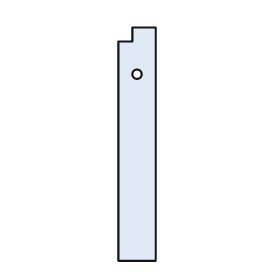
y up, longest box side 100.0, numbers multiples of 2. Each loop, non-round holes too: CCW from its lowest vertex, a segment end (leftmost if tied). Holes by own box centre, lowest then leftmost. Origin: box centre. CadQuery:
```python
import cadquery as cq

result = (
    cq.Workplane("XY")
    .moveTo(-8.0, -50.0)
    .lineTo(8.0, -50.0)
    .lineTo(8.0, 50.0)
    .lineTo(-2.0, 50.0)
    .lineTo(-2.0, 44.0)
    .lineTo(-8.0, 44.0)
    .close()
    .moveTo(0.0, 30.0)
    .circle(2.0)
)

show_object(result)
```